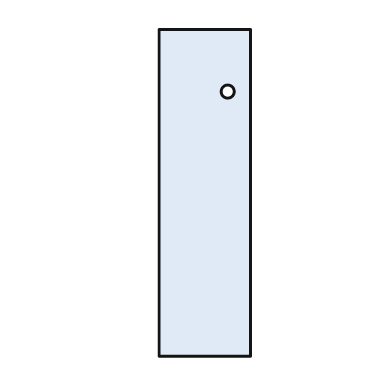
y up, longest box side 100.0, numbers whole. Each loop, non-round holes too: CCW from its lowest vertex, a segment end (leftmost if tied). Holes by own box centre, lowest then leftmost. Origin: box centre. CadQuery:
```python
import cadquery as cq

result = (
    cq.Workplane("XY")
    .moveTo(-14.0, -50.0)
    .lineTo(14.0, -50.0)
    .lineTo(14.0, 50.0)
    .lineTo(-14.0, 50.0)
    .close()
    .moveTo(7.0, 31.0)
    .circle(2.0)
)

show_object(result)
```